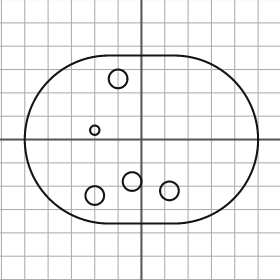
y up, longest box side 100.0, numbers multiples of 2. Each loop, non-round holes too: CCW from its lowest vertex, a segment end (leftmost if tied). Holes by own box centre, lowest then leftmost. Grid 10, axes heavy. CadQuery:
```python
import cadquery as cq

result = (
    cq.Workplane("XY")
    .moveTo(-14.0, -36.0)
    .lineTo(14.0, -36.0)
    .threePointArc((50.0, 0.0), (14.0, 36.0))
    .lineTo(-14.0, 36.0)
    .threePointArc((-50.0, 0.0), (-14.0, -36.0))
    .close()
    .moveTo(-20.0, -24.0)
    .circle(4.0)
    .moveTo(12.0, -22.0)
    .circle(4.0)
    .moveTo(-4.0, -18.0)
    .circle(4.0)
    .moveTo(-20.0, 4.0)
    .circle(2.0)
    .moveTo(-10.0, 26.0)
    .circle(4.0)
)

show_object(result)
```